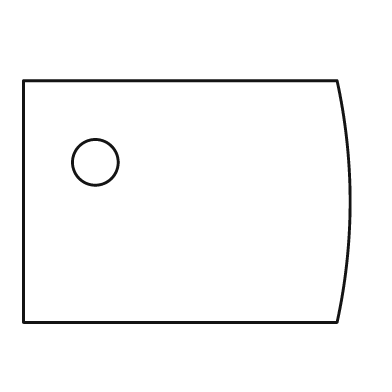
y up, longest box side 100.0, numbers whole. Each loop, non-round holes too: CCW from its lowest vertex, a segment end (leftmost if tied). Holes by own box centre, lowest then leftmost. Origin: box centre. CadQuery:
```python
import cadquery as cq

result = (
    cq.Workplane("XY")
    .moveTo(-50.0, -37.0)
    .lineTo(46.0, -37.0)
    .threePointArc((50.0, 0.0), (46.0, 37.0))
    .lineTo(-50.0, 37.0)
    .close()
    .moveTo(-28.0, 12.0)
    .circle(7.0)
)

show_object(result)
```